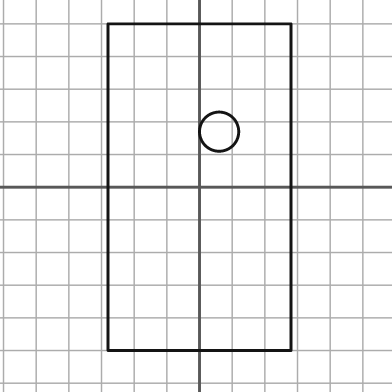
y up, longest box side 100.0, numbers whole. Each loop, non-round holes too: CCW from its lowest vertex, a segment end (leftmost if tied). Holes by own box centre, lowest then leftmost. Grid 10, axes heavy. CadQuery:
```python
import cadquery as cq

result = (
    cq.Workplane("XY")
    .moveTo(-28.0, -50.0)
    .lineTo(28.0, -50.0)
    .lineTo(28.0, 50.0)
    .lineTo(-28.0, 50.0)
    .close()
    .moveTo(6.0, 17.0)
    .circle(6.0)
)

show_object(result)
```